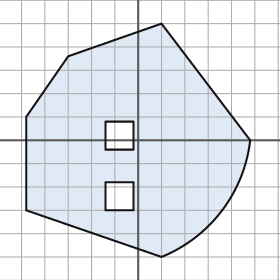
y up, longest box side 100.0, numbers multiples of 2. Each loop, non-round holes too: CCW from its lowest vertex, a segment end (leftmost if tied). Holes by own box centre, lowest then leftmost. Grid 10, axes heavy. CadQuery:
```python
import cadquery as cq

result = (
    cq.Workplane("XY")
    .moveTo(10.0, -50.0)
    .threePointArc((36.0, -30.0), (48.0, 0.0))
    .lineTo(10.0, 50.0)
    .lineTo(-30.0, 36.0)
    .lineTo(-48.0, 10.0)
    .lineTo(-48.0, -30.0)
    .close()
    .moveTo(-14.0, -30.0)
    .lineTo(-2.0, -30.0)
    .lineTo(-2.0, -18.0)
    .lineTo(-14.0, -18.0)
    .close()
    .moveTo(-14.0, -4.0)
    .lineTo(-2.0, -4.0)
    .lineTo(-2.0, 8.0)
    .lineTo(-14.0, 8.0)
    .close()
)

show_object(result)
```